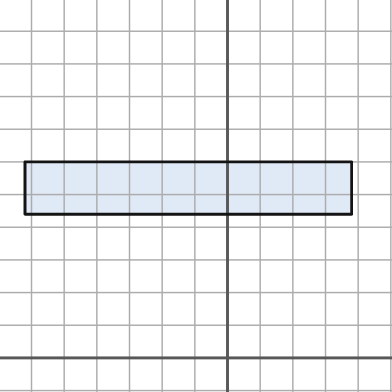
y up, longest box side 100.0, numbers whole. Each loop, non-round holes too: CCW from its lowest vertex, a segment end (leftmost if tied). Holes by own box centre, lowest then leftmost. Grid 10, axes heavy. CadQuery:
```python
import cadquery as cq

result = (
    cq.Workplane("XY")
    .moveTo(-62.0, 44.0)
    .lineTo(38.0, 44.0)
    .lineTo(38.0, 60.0)
    .lineTo(-62.0, 60.0)
    .close()
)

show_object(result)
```